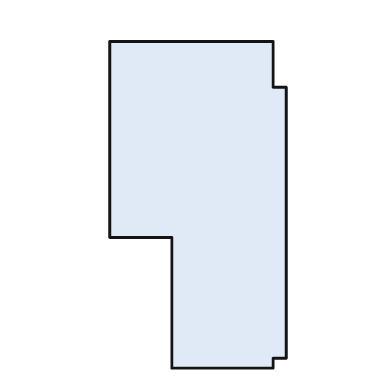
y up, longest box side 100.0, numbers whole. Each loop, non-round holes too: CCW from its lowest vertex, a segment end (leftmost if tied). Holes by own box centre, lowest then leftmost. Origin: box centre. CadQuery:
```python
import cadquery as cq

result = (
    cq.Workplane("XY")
    .moveTo(-8.0, -50.0)
    .lineTo(23.0, -50.0)
    .lineTo(23.0, -47.0)
    .lineTo(27.0, -47.0)
    .lineTo(27.0, 36.0)
    .lineTo(23.0, 36.0)
    .lineTo(23.0, 50.0)
    .lineTo(-27.0, 50.0)
    .lineTo(-27.0, -10.0)
    .lineTo(-8.0, -10.0)
    .close()
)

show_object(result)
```